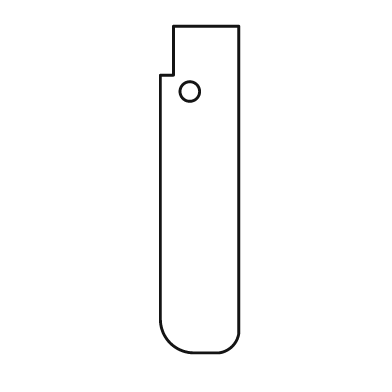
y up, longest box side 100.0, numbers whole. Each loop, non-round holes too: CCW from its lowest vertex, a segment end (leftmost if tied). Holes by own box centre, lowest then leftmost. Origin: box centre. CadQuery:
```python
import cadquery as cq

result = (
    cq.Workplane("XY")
    .moveTo(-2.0, -50.0)
    .lineTo(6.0, -50.0)
    .threePointArc((10.0, -48.0), (12.0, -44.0))
    .lineTo(12.0, 50.0)
    .lineTo(-8.0, 50.0)
    .lineTo(-8.0, 35.0)
    .lineTo(-12.0, 35.0)
    .lineTo(-12.0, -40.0)
    .threePointArc((-9.0, -47.0), (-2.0, -50.0))
    .close()
    .moveTo(-3.0, 30.0)
    .circle(3.0)
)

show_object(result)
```